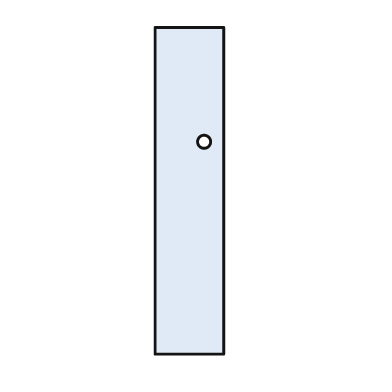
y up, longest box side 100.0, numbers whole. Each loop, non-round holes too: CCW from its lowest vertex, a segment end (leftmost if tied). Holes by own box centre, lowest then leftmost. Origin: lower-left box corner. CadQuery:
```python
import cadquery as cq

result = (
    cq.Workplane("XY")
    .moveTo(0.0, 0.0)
    .lineTo(21.0, 0.0)
    .lineTo(21.0, 100.0)
    .lineTo(0.0, 100.0)
    .close()
    .moveTo(15.0, 65.0)
    .circle(2.0)
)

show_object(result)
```